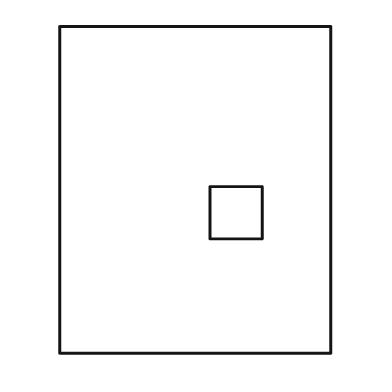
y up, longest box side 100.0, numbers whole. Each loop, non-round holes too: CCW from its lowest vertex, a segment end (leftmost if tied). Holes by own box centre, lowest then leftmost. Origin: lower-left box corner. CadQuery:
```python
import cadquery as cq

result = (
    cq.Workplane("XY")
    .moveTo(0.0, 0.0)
    .lineTo(83.0, 0.0)
    .lineTo(83.0, 100.0)
    .lineTo(0.0, 100.0)
    .close()
    .moveTo(46.0, 35.0)
    .lineTo(62.0, 35.0)
    .lineTo(62.0, 51.0)
    .lineTo(46.0, 51.0)
    .close()
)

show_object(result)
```